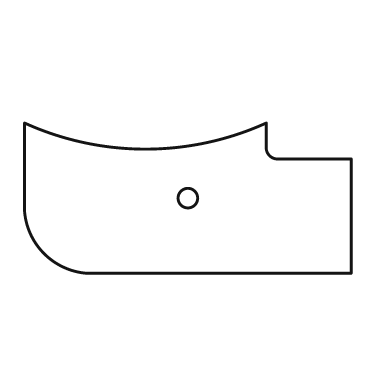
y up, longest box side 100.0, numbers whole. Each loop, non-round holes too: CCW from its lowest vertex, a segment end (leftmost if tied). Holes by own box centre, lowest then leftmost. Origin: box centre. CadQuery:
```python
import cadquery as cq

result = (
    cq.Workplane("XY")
    .moveTo(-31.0, -23.0)
    .lineTo(50.0, -23.0)
    .lineTo(50.0, 12.0)
    .lineTo(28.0, 12.0)
    .threePointArc((25.0, 13.0), (24.0, 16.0))
    .lineTo(24.0, 23.0)
    .threePointArc((-13.0, 15.0), (-50.0, 23.0))
    .lineTo(-50.0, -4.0)
    .threePointArc((-44.0, -17.0), (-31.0, -23.0))
    .close()
    .moveTo(0.0, 0.0)
    .circle(3.0)
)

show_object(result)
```